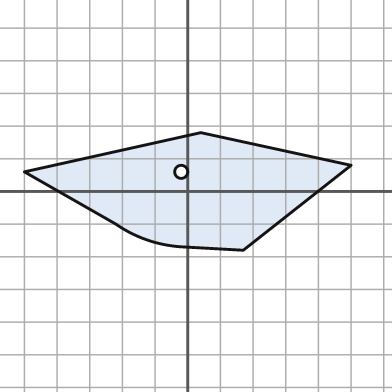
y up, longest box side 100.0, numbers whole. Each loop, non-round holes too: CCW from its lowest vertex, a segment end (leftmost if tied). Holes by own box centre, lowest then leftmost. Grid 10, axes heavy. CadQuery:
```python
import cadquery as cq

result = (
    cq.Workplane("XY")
    .moveTo(17.0, -18.0)
    .lineTo(50.0, 8.0)
    .lineTo(4.0, 18.0)
    .lineTo(-50.0, 6.0)
    .lineTo(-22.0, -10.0)
    .threePointArc((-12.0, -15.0), (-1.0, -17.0))
    .close()
    .moveTo(-2.0, 6.0)
    .circle(2.0)
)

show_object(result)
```